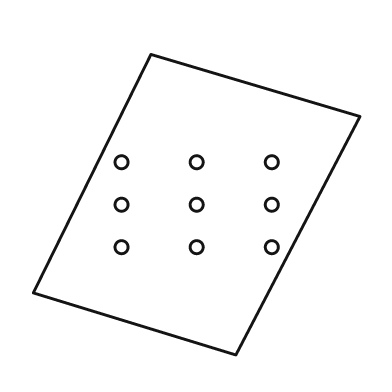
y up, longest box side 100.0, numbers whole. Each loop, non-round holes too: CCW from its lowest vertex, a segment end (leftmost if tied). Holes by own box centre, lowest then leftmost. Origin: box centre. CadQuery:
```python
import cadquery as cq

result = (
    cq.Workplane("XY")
    .moveTo(12.0, -46.0)
    .lineTo(50.0, 27.0)
    .lineTo(-14.0, 46.0)
    .lineTo(-50.0, -27.0)
    .close()
    .moveTo(-23.0, -13.0)
    .circle(2.0)
    .moveTo(0.0, -13.0)
    .circle(2.0)
    .moveTo(23.0, -13.0)
    .circle(2.0)
    .moveTo(-23.0, 0.0)
    .circle(2.0)
    .moveTo(0.0, 0.0)
    .circle(2.0)
    .moveTo(23.0, 0.0)
    .circle(2.0)
    .moveTo(-23.0, 13.0)
    .circle(2.0)
    .moveTo(0.0, 13.0)
    .circle(2.0)
    .moveTo(23.0, 13.0)
    .circle(2.0)
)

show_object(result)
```